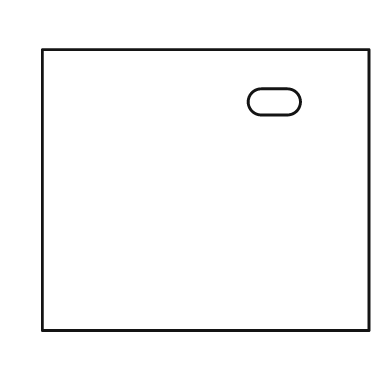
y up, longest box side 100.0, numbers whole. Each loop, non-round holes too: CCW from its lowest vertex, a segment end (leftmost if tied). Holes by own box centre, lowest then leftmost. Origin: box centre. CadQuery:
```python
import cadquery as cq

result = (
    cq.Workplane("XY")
    .moveTo(-50.0, -43.0)
    .lineTo(50.0, -43.0)
    .lineTo(50.0, 43.0)
    .lineTo(-50.0, 43.0)
    .close()
    .moveTo(17.0, 23.0)
    .lineTo(25.0, 23.0)
    .threePointArc((29.0, 27.0), (25.0, 31.0))
    .lineTo(17.0, 31.0)
    .threePointArc((13.0, 27.0), (17.0, 23.0))
    .close()
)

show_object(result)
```